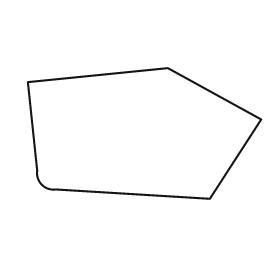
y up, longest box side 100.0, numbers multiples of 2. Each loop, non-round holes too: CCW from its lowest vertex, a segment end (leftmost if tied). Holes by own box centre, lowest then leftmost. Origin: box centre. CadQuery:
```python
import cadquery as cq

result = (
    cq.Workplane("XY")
    .moveTo(28.0, -28.0)
    .lineTo(50.0, 6.0)
    .lineTo(10.0, 28.0)
    .lineTo(-50.0, 22.0)
    .lineTo(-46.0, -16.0)
    .threePointArc((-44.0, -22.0), (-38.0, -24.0))
    .close()
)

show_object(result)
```